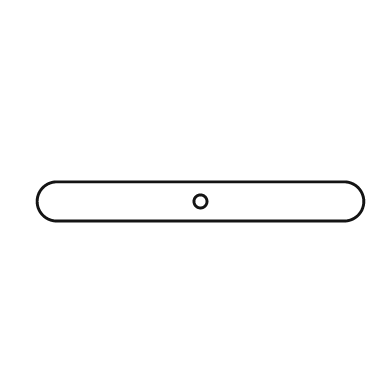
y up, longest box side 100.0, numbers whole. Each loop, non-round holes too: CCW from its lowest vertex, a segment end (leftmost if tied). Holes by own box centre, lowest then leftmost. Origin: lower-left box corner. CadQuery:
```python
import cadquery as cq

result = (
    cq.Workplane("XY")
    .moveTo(6.0, 0.0)
    .lineTo(94.0, 0.0)
    .threePointArc((100.0, 6.0), (94.0, 12.0))
    .lineTo(6.0, 12.0)
    .threePointArc((0.0, 6.0), (6.0, 0.0))
    .close()
    .moveTo(50.0, 6.0)
    .circle(2.0)
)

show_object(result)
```